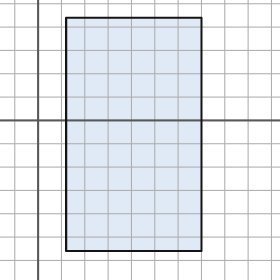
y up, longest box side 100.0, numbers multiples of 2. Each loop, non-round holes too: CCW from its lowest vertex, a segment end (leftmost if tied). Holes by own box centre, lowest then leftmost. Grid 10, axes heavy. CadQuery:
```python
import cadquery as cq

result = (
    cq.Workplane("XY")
    .moveTo(12.0, -56.0)
    .lineTo(70.0, -56.0)
    .lineTo(70.0, 44.0)
    .lineTo(12.0, 44.0)
    .close()
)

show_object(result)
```